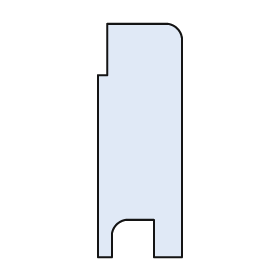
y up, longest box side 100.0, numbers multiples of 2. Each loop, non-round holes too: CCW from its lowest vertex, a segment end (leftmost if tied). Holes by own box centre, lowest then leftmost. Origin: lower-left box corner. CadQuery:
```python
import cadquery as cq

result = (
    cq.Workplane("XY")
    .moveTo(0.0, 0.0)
    .lineTo(6.0, 0.0)
    .lineTo(6.0, 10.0)
    .threePointArc((8.0, 14.0), (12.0, 16.0))
    .lineTo(24.0, 16.0)
    .lineTo(24.0, 0.0)
    .lineTo(36.0, 0.0)
    .lineTo(36.0, 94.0)
    .threePointArc((34.0, 98.0), (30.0, 100.0))
    .lineTo(4.0, 100.0)
    .lineTo(4.0, 78.0)
    .lineTo(0.0, 78.0)
    .close()
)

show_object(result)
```